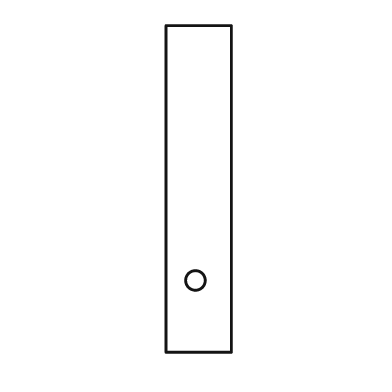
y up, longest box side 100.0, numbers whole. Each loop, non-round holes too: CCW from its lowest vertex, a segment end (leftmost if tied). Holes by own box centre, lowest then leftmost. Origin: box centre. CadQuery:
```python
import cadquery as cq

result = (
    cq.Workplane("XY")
    .moveTo(-10.0, -50.0)
    .lineTo(10.0, -50.0)
    .lineTo(10.0, 50.0)
    .lineTo(-10.0, 50.0)
    .close()
    .moveTo(-1.0, -28.0)
    .circle(3.0)
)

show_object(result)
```